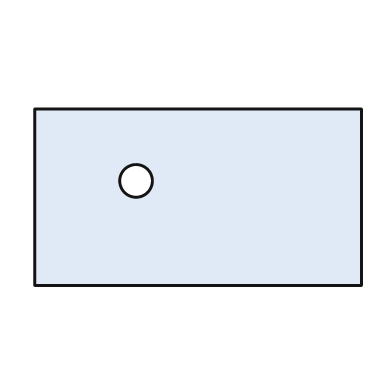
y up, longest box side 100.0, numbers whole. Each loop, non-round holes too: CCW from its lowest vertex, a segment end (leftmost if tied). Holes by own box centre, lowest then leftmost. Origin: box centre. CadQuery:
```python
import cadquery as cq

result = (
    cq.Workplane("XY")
    .moveTo(-50.0, -27.0)
    .lineTo(50.0, -27.0)
    .lineTo(50.0, 27.0)
    .lineTo(-50.0, 27.0)
    .close()
    .moveTo(-19.0, 5.0)
    .circle(5.0)
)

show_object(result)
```